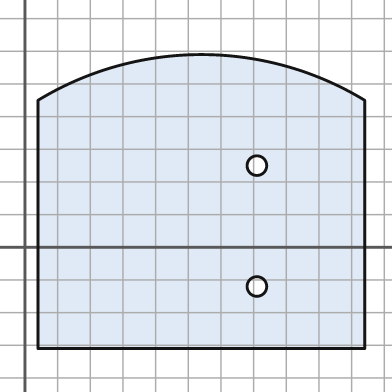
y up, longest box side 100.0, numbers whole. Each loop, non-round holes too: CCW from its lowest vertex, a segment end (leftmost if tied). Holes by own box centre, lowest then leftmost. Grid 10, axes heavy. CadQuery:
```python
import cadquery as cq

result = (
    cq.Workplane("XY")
    .moveTo(4.0, -31.0)
    .lineTo(104.0, -31.0)
    .lineTo(104.0, 45.0)
    .threePointArc((54.0, 59.0), (4.0, 45.0))
    .close()
    .moveTo(71.0, -12.0)
    .circle(3.0)
    .moveTo(71.0, 25.0)
    .circle(3.0)
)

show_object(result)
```